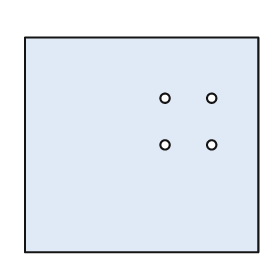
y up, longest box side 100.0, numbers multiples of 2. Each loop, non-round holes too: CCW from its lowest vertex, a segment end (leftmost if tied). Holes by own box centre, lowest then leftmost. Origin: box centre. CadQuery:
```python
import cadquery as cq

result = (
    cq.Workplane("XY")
    .moveTo(-50.0, -46.0)
    .lineTo(50.0, -46.0)
    .lineTo(50.0, 46.0)
    .lineTo(-50.0, 46.0)
    .close()
    .moveTo(10.0, 0.0)
    .circle(2.0)
    .moveTo(30.0, 0.0)
    .circle(2.0)
    .moveTo(10.0, 20.0)
    .circle(2.0)
    .moveTo(30.0, 20.0)
    .circle(2.0)
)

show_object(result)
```